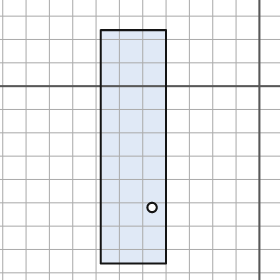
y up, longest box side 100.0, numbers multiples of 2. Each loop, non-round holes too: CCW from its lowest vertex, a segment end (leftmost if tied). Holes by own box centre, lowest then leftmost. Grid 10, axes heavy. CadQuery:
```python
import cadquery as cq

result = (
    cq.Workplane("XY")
    .moveTo(-68.0, -76.0)
    .lineTo(-40.0, -76.0)
    .lineTo(-40.0, 24.0)
    .lineTo(-68.0, 24.0)
    .close()
    .moveTo(-46.0, -52.0)
    .circle(2.0)
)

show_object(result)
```